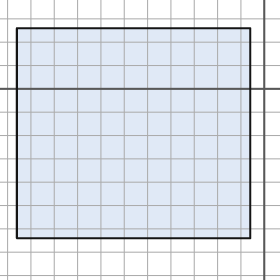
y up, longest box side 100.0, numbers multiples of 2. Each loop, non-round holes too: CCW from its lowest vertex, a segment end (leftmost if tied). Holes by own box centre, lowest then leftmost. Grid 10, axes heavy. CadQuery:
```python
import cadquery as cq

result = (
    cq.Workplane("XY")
    .moveTo(-106.0, -64.0)
    .lineTo(-6.0, -64.0)
    .lineTo(-6.0, 26.0)
    .lineTo(-106.0, 26.0)
    .close()
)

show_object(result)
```